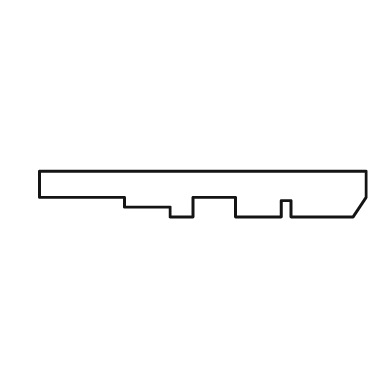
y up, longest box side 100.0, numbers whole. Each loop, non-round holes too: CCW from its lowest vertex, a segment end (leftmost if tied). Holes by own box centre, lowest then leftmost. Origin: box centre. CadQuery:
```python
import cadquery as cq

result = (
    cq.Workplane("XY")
    .moveTo(-10.0, -7.0)
    .lineTo(-3.0, -7.0)
    .lineTo(-3.0, -1.0)
    .lineTo(10.0, -1.0)
    .lineTo(10.0, -7.0)
    .lineTo(24.0, -7.0)
    .lineTo(24.0, -2.0)
    .lineTo(27.0, -2.0)
    .lineTo(27.0, -7.0)
    .lineTo(46.0, -7.0)
    .lineTo(50.0, -1.0)
    .lineTo(50.0, 7.0)
    .lineTo(-50.0, 7.0)
    .lineTo(-50.0, -1.0)
    .lineTo(-24.0, -1.0)
    .lineTo(-24.0, -4.0)
    .lineTo(-10.0, -4.0)
    .close()
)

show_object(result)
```